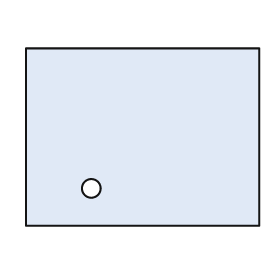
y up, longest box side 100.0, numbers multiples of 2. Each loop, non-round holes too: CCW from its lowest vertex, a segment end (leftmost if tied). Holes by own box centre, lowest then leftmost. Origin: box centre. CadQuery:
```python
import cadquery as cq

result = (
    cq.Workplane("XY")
    .moveTo(-50.0, -38.0)
    .lineTo(50.0, -38.0)
    .lineTo(50.0, 38.0)
    .lineTo(-50.0, 38.0)
    .close()
    .moveTo(-22.0, -22.0)
    .circle(4.0)
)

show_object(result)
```